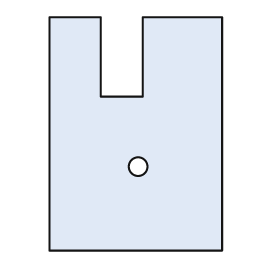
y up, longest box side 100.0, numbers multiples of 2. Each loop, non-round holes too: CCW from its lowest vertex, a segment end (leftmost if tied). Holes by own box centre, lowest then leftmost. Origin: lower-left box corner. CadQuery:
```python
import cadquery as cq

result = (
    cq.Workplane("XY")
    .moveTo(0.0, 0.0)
    .lineTo(74.0, 0.0)
    .lineTo(74.0, 100.0)
    .lineTo(40.0, 100.0)
    .lineTo(40.0, 66.0)
    .lineTo(22.0, 66.0)
    .lineTo(22.0, 100.0)
    .lineTo(0.0, 100.0)
    .close()
    .moveTo(38.0, 36.0)
    .circle(4.0)
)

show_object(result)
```